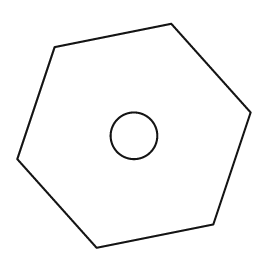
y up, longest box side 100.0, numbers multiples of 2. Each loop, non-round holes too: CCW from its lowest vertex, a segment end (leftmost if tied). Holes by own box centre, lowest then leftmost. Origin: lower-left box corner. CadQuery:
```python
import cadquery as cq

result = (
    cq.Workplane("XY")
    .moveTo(34.0, 0.0)
    .lineTo(84.0, 10.0)
    .lineTo(100.0, 58.0)
    .lineTo(66.0, 96.0)
    .lineTo(16.0, 86.0)
    .lineTo(0.0, 38.0)
    .close()
    .moveTo(50.0, 48.0)
    .circle(10.0)
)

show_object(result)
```